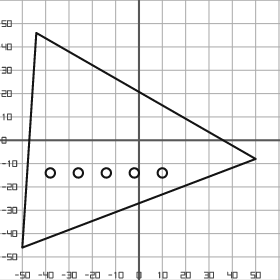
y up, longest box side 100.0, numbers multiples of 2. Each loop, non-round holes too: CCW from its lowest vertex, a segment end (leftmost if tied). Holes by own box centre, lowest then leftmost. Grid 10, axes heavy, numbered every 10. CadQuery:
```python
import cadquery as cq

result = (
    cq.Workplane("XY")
    .moveTo(-50.0, -46.0)
    .lineTo(50.0, -8.0)
    .lineTo(-44.0, 46.0)
    .close()
    .moveTo(-38.0, -14.0)
    .circle(2.0)
    .moveTo(-26.0, -14.0)
    .circle(2.0)
    .moveTo(-14.0, -14.0)
    .circle(2.0)
    .moveTo(-2.0, -14.0)
    .circle(2.0)
    .moveTo(10.0, -14.0)
    .circle(2.0)
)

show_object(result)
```